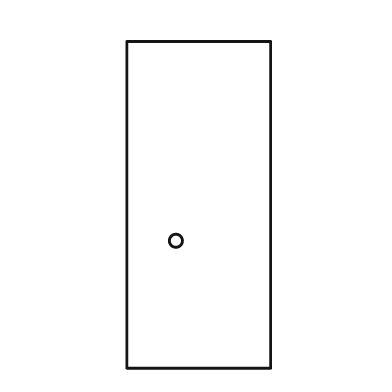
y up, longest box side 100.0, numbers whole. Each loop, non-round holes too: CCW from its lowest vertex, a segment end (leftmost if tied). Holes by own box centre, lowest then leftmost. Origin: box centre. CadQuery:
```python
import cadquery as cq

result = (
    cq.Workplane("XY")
    .moveTo(-22.0, -50.0)
    .lineTo(22.0, -50.0)
    .lineTo(22.0, 50.0)
    .lineTo(-22.0, 50.0)
    .close()
    .moveTo(-7.0, -11.0)
    .circle(2.0)
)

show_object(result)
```